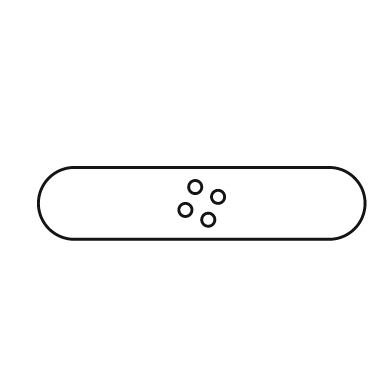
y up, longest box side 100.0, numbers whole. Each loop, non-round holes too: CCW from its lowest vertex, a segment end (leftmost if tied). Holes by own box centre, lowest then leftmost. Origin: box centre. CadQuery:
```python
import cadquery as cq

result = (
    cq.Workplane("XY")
    .moveTo(-39.0, -11.0)
    .lineTo(39.0, -11.0)
    .threePointArc((50.0, 0.0), (39.0, 11.0))
    .lineTo(-39.0, 11.0)
    .threePointArc((-50.0, 0.0), (-39.0, -11.0))
    .close()
    .moveTo(2.0, -5.0)
    .circle(2.0)
    .moveTo(-5.0, -2.0)
    .circle(2.0)
    .moveTo(5.0, 2.0)
    .circle(2.0)
    .moveTo(-2.0, 5.0)
    .circle(2.0)
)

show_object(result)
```